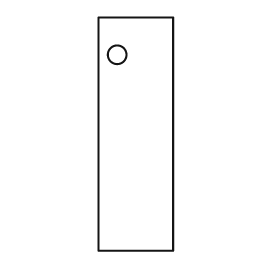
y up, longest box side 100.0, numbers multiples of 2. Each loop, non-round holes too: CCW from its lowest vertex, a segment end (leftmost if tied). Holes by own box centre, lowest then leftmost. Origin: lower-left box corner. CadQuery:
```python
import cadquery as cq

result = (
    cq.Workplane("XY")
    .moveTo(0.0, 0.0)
    .lineTo(32.0, 0.0)
    .lineTo(32.0, 100.0)
    .lineTo(0.0, 100.0)
    .close()
    .moveTo(8.0, 84.0)
    .circle(4.0)
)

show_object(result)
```